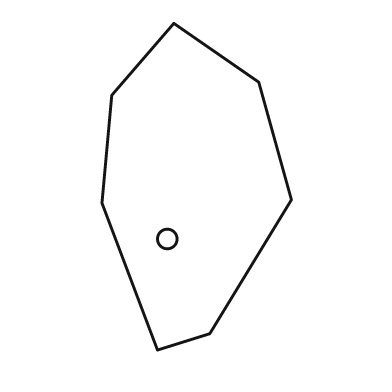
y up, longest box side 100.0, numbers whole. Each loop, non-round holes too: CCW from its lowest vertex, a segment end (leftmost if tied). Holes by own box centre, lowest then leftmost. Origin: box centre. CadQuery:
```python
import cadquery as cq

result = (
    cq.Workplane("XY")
    .moveTo(-12.0, -50.0)
    .lineTo(4.0, -45.0)
    .lineTo(29.0, -4.0)
    .lineTo(19.0, 32.0)
    .lineTo(-7.0, 50.0)
    .lineTo(-26.0, 28.0)
    .lineTo(-29.0, -5.0)
    .close()
    .moveTo(-9.0, -16.0)
    .circle(3.0)
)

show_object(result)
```